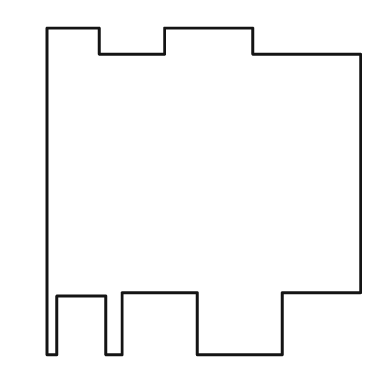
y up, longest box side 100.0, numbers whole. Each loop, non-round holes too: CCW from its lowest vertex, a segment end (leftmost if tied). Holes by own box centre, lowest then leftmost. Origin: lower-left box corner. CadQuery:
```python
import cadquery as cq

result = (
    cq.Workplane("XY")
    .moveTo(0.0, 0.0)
    .lineTo(3.0, 0.0)
    .lineTo(3.0, 18.0)
    .lineTo(18.0, 18.0)
    .lineTo(18.0, 0.0)
    .lineTo(23.0, 0.0)
    .lineTo(23.0, 19.0)
    .lineTo(46.0, 19.0)
    .lineTo(46.0, 0.0)
    .lineTo(72.0, 0.0)
    .lineTo(72.0, 19.0)
    .lineTo(96.0, 19.0)
    .lineTo(96.0, 92.0)
    .lineTo(63.0, 92.0)
    .lineTo(63.0, 100.0)
    .lineTo(36.0, 100.0)
    .lineTo(36.0, 92.0)
    .lineTo(16.0, 92.0)
    .lineTo(16.0, 100.0)
    .lineTo(0.0, 100.0)
    .close()
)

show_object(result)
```